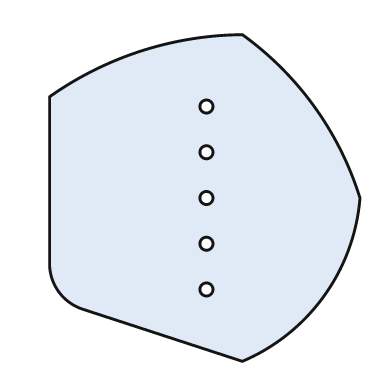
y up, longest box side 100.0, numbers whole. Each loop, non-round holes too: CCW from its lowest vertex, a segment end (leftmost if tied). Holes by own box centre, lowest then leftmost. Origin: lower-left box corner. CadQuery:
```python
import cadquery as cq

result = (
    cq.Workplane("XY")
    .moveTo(59.0, 0.0)
    .threePointArc((84.0, 20.0), (95.0, 50.0))
    .threePointArc((81.0, 78.0), (59.0, 100.0))
    .threePointArc((28.0, 95.0), (0.0, 81.0))
    .lineTo(0.0, 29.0)
    .threePointArc((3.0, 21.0), (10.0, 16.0))
    .close()
    .moveTo(48.0, 22.0)
    .circle(2.0)
    .moveTo(48.0, 36.0)
    .circle(2.0)
    .moveTo(48.0, 50.0)
    .circle(2.0)
    .moveTo(48.0, 64.0)
    .circle(2.0)
    .moveTo(48.0, 78.0)
    .circle(2.0)
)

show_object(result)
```